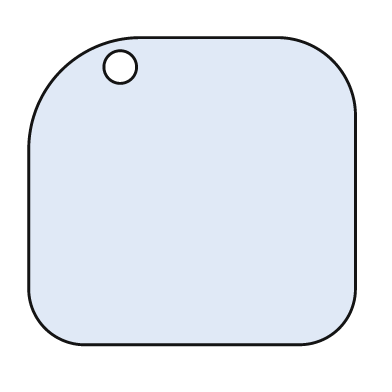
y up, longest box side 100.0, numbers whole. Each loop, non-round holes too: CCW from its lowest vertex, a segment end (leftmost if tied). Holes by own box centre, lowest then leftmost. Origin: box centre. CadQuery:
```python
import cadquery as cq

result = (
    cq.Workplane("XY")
    .moveTo(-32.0, -47.0)
    .lineTo(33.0, -47.0)
    .threePointArc((45.0, -42.0), (50.0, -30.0))
    .lineTo(50.0, 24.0)
    .threePointArc((43.0, 40.0), (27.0, 47.0))
    .lineTo(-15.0, 47.0)
    .threePointArc((-40.0, 37.0), (-50.0, 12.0))
    .lineTo(-50.0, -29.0)
    .threePointArc((-45.0, -42.0), (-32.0, -47.0))
    .close()
    .moveTo(-22.0, 38.0)
    .circle(5.0)
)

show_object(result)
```